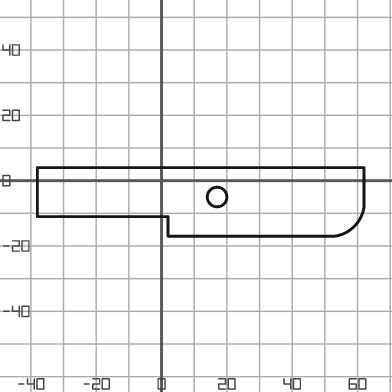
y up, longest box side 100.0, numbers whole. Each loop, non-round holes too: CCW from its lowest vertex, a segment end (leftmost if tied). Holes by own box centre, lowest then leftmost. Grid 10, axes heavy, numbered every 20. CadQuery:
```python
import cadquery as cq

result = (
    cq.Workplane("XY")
    .moveTo(2.0, -17.0)
    .lineTo(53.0, -17.0)
    .threePointArc((59.0, -14.0), (62.0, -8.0))
    .lineTo(62.0, 4.0)
    .lineTo(-38.0, 4.0)
    .lineTo(-38.0, -11.0)
    .lineTo(2.0, -11.0)
    .close()
    .moveTo(17.0, -5.0)
    .circle(3.0)
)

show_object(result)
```